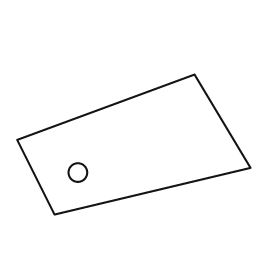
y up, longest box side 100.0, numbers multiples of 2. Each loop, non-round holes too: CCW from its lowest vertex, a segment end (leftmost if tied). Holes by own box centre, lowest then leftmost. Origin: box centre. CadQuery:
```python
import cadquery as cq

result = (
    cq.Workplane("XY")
    .moveTo(-34.0, -30.0)
    .lineTo(50.0, -10.0)
    .lineTo(26.0, 30.0)
    .lineTo(-50.0, 2.0)
    .close()
    .moveTo(-24.0, -12.0)
    .circle(4.0)
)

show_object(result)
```